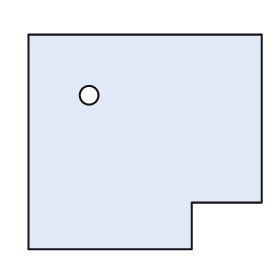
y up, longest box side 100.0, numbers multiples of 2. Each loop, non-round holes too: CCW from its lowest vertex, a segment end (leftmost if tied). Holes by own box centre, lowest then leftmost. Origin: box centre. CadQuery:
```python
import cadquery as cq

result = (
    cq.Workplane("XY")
    .moveTo(-50.0, -46.0)
    .lineTo(20.0, -46.0)
    .lineTo(20.0, -26.0)
    .lineTo(50.0, -26.0)
    .lineTo(50.0, 46.0)
    .lineTo(-50.0, 46.0)
    .close()
    .moveTo(-24.0, 20.0)
    .circle(4.0)
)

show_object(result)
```